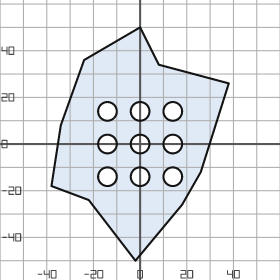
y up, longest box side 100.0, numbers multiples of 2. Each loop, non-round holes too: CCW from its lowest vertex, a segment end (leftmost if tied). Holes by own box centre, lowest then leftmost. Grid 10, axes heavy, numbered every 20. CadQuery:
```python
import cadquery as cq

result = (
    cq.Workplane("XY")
    .moveTo(-2.0, -50.0)
    .lineTo(18.0, -26.0)
    .lineTo(26.0, -12.0)
    .lineTo(38.0, 26.0)
    .lineTo(8.0, 34.0)
    .lineTo(0.0, 50.0)
    .lineTo(-24.0, 36.0)
    .lineTo(-34.0, 8.0)
    .lineTo(-38.0, -18.0)
    .lineTo(-22.0, -24.0)
    .close()
    .moveTo(-14.0, -14.0)
    .circle(4.0)
    .moveTo(0.0, -14.0)
    .circle(4.0)
    .moveTo(14.0, -14.0)
    .circle(4.0)
    .moveTo(-14.0, 0.0)
    .circle(4.0)
    .moveTo(0.0, 0.0)
    .circle(4.0)
    .moveTo(14.0, 0.0)
    .circle(4.0)
    .moveTo(-14.0, 14.0)
    .circle(4.0)
    .moveTo(0.0, 14.0)
    .circle(4.0)
    .moveTo(14.0, 14.0)
    .circle(4.0)
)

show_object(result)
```